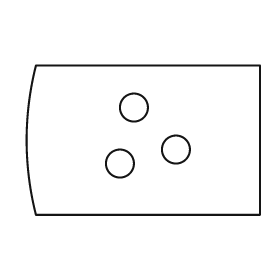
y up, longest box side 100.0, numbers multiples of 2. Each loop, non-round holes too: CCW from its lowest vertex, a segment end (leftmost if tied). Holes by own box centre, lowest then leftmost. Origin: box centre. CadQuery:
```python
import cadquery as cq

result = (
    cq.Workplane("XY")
    .moveTo(-46.0, -32.0)
    .lineTo(50.0, -32.0)
    .lineTo(50.0, 32.0)
    .lineTo(-46.0, 32.0)
    .threePointArc((-50.0, 0.0), (-46.0, -32.0))
    .close()
    .moveTo(-10.0, -10.0)
    .circle(6.0)
    .moveTo(14.0, -4.0)
    .circle(6.0)
    .moveTo(-4.0, 14.0)
    .circle(6.0)
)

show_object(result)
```